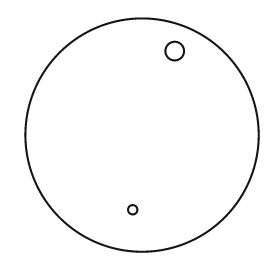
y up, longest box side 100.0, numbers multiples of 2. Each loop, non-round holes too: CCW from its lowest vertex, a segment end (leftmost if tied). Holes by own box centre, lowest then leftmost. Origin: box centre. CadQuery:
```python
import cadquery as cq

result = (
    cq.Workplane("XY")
    .moveTo(0.0, 0.0)
    .circle(50.0)
    .moveTo(-4.0, -32.0)
    .circle(2.0)
    .moveTo(14.0, 36.0)
    .circle(4.0)
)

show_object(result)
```